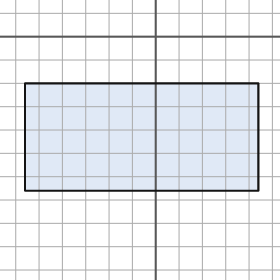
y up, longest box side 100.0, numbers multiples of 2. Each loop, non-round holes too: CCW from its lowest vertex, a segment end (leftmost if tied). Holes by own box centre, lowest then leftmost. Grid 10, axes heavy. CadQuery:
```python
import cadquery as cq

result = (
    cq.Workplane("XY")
    .moveTo(-56.0, -66.0)
    .lineTo(44.0, -66.0)
    .lineTo(44.0, -20.0)
    .lineTo(-56.0, -20.0)
    .close()
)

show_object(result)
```